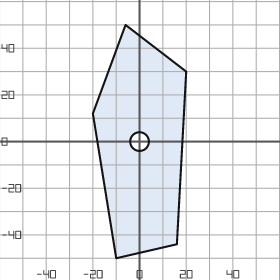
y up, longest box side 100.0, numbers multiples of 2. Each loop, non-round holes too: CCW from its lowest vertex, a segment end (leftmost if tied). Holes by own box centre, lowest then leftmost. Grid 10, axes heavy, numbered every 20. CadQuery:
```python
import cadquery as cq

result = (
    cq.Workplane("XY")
    .moveTo(-10.0, -50.0)
    .lineTo(16.0, -44.0)
    .lineTo(20.0, 30.0)
    .lineTo(-6.0, 50.0)
    .lineTo(-20.0, 12.0)
    .close()
    .moveTo(0.0, 0.0)
    .circle(4.0)
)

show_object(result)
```